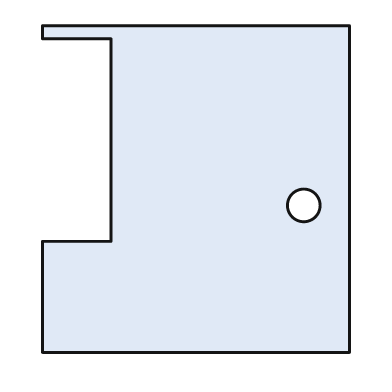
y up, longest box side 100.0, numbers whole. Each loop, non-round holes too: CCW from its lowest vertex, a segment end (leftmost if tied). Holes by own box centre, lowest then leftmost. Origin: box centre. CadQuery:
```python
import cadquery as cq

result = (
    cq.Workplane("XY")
    .moveTo(-47.0, -50.0)
    .lineTo(47.0, -50.0)
    .lineTo(47.0, 50.0)
    .lineTo(-47.0, 50.0)
    .lineTo(-47.0, 46.0)
    .lineTo(-26.0, 46.0)
    .lineTo(-26.0, -16.0)
    .lineTo(-47.0, -16.0)
    .close()
    .moveTo(33.0, -5.0)
    .circle(5.0)
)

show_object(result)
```